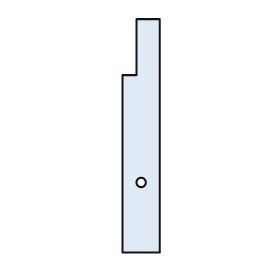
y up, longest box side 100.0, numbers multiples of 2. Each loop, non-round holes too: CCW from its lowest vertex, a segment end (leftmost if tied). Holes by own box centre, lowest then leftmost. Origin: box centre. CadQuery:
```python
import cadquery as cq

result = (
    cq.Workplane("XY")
    .moveTo(-8.0, -50.0)
    .lineTo(8.0, -50.0)
    .lineTo(8.0, 50.0)
    .lineTo(-2.0, 50.0)
    .lineTo(-2.0, 26.0)
    .lineTo(-8.0, 26.0)
    .close()
    .moveTo(0.0, -20.0)
    .circle(2.0)
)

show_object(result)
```